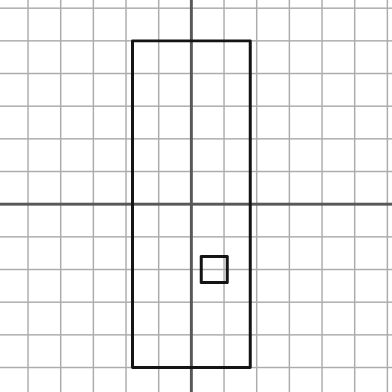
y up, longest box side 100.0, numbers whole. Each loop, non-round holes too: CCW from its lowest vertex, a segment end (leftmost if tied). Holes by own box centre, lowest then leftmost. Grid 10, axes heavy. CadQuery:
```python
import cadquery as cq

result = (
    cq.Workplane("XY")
    .moveTo(-18.0, -50.0)
    .lineTo(18.0, -50.0)
    .lineTo(18.0, 50.0)
    .lineTo(-18.0, 50.0)
    .close()
    .moveTo(3.0, -24.0)
    .lineTo(11.0, -24.0)
    .lineTo(11.0, -16.0)
    .lineTo(3.0, -16.0)
    .close()
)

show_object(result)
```